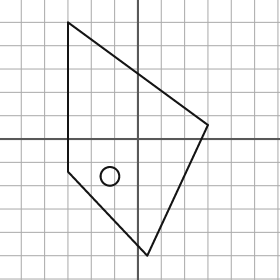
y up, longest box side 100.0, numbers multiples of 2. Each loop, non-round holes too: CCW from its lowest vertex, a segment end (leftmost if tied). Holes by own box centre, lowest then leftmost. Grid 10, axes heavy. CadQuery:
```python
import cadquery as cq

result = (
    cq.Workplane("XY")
    .moveTo(4.0, -50.0)
    .lineTo(30.0, 6.0)
    .lineTo(-30.0, 50.0)
    .lineTo(-30.0, -14.0)
    .close()
    .moveTo(-12.0, -16.0)
    .circle(4.0)
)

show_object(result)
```